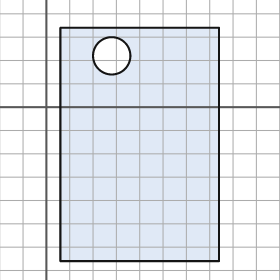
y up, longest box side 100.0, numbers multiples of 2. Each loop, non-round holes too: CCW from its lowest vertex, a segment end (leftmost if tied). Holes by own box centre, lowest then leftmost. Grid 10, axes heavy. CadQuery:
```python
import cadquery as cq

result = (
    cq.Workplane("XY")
    .moveTo(6.0, -66.0)
    .lineTo(74.0, -66.0)
    .lineTo(74.0, 34.0)
    .lineTo(6.0, 34.0)
    .close()
    .moveTo(28.0, 22.0)
    .circle(8.0)
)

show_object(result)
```